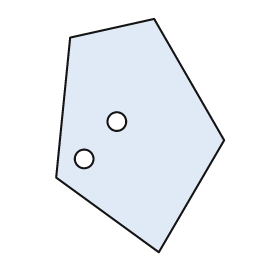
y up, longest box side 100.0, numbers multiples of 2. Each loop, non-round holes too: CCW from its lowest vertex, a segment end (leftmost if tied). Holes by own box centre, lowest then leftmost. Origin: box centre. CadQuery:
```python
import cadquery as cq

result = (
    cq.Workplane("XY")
    .moveTo(8.0, -50.0)
    .lineTo(36.0, -2.0)
    .lineTo(6.0, 50.0)
    .lineTo(-30.0, 42.0)
    .lineTo(-36.0, -18.0)
    .close()
    .moveTo(-24.0, -10.0)
    .circle(4.0)
    .moveTo(-10.0, 6.0)
    .circle(4.0)
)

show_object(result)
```